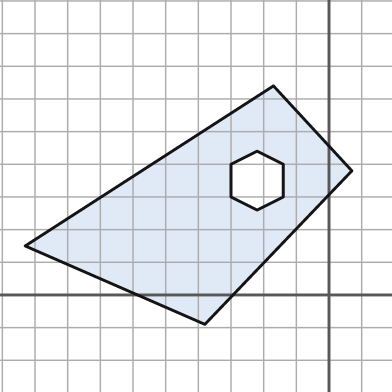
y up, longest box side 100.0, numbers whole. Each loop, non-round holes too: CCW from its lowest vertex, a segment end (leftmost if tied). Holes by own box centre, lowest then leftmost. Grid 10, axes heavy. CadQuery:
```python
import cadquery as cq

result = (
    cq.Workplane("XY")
    .moveTo(-38.0, -9.0)
    .lineTo(7.0, 38.0)
    .lineTo(-17.0, 64.0)
    .lineTo(-93.0, 15.0)
    .close()
    .moveTo(-22.0, 26.0)
    .lineTo(-14.0, 30.0)
    .lineTo(-14.0, 40.0)
    .lineTo(-22.0, 44.0)
    .lineTo(-30.0, 40.0)
    .lineTo(-30.0, 30.0)
    .close()
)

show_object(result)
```